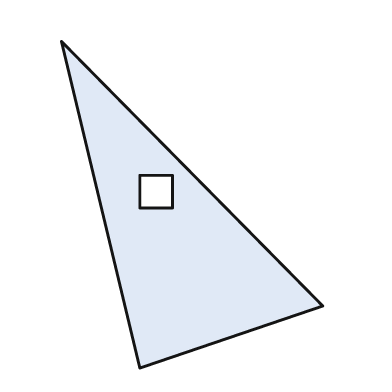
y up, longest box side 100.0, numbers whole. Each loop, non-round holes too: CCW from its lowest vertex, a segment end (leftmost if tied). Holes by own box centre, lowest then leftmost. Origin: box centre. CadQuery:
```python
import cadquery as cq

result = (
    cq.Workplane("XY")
    .moveTo(-16.0, -50.0)
    .lineTo(40.0, -31.0)
    .lineTo(-40.0, 50.0)
    .close()
    .moveTo(-16.0, -1.0)
    .lineTo(-6.0, -1.0)
    .lineTo(-6.0, 9.0)
    .lineTo(-16.0, 9.0)
    .close()
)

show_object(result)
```